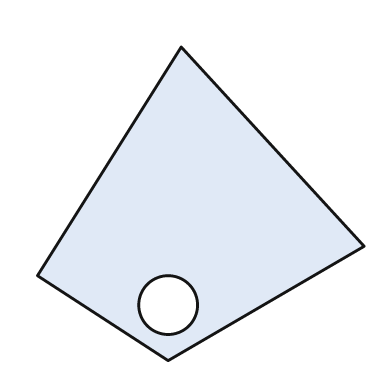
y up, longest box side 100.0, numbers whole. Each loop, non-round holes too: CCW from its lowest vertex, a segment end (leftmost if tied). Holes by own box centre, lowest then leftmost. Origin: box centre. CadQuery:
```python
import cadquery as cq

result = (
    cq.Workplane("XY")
    .moveTo(-10.0, -48.0)
    .lineTo(50.0, -13.0)
    .lineTo(-6.0, 48.0)
    .lineTo(-50.0, -22.0)
    .close()
    .moveTo(-10.0, -31.0)
    .circle(9.0)
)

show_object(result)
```